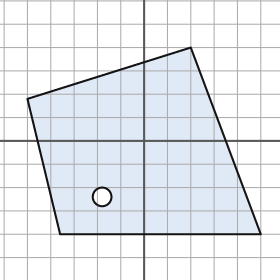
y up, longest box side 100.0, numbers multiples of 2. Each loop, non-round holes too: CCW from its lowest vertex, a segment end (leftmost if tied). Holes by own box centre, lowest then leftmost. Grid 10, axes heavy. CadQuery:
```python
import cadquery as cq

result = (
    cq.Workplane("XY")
    .moveTo(-36.0, -40.0)
    .lineTo(50.0, -40.0)
    .lineTo(20.0, 40.0)
    .lineTo(-50.0, 18.0)
    .close()
    .moveTo(-18.0, -24.0)
    .circle(4.0)
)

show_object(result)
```